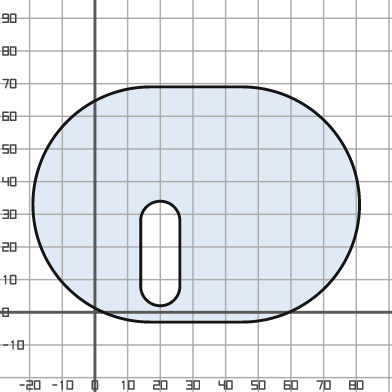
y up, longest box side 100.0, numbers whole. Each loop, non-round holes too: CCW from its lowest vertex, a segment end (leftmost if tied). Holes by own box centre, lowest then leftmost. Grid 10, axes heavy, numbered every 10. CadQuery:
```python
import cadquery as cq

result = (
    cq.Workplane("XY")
    .moveTo(17.0, -3.0)
    .lineTo(45.0, -3.0)
    .threePointArc((81.0, 33.0), (45.0, 69.0))
    .lineTo(17.0, 69.0)
    .threePointArc((-19.0, 33.0), (17.0, -3.0))
    .close()
    .moveTo(14.0, 8.0)
    .threePointArc((20.0, 2.0), (26.0, 8.0))
    .lineTo(26.0, 28.0)
    .threePointArc((20.0, 34.0), (14.0, 28.0))
    .close()
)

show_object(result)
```